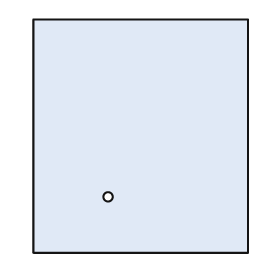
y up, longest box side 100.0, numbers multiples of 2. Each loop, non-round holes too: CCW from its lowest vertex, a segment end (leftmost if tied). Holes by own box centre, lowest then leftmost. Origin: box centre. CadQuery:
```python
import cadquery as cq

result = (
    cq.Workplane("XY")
    .moveTo(-46.0, -50.0)
    .lineTo(46.0, -50.0)
    .lineTo(46.0, 50.0)
    .lineTo(-46.0, 50.0)
    .close()
    .moveTo(-14.0, -26.0)
    .circle(2.0)
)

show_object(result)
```